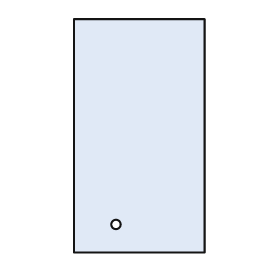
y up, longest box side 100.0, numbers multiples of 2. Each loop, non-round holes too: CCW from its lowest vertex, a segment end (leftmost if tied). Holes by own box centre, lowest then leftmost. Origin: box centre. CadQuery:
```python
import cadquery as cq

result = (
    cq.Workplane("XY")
    .moveTo(-28.0, -50.0)
    .lineTo(28.0, -50.0)
    .lineTo(28.0, 50.0)
    .lineTo(-28.0, 50.0)
    .close()
    .moveTo(-10.0, -38.0)
    .circle(2.0)
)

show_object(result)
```